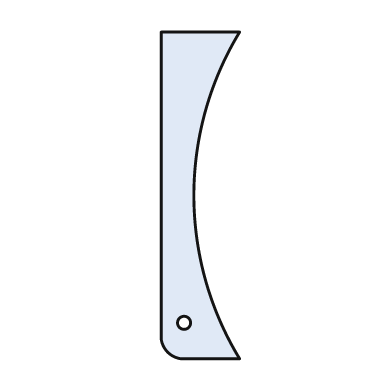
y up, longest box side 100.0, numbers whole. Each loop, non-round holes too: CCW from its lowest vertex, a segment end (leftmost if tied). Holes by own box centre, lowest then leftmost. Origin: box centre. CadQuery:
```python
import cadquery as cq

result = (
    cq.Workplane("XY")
    .moveTo(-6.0, -50.0)
    .lineTo(12.0, -50.0)
    .threePointArc((-2.0, 0.0), (12.0, 50.0))
    .lineTo(-12.0, 50.0)
    .lineTo(-12.0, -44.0)
    .threePointArc((-10.0, -48.0), (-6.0, -50.0))
    .close()
    .moveTo(-5.0, -39.0)
    .circle(2.0)
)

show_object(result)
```